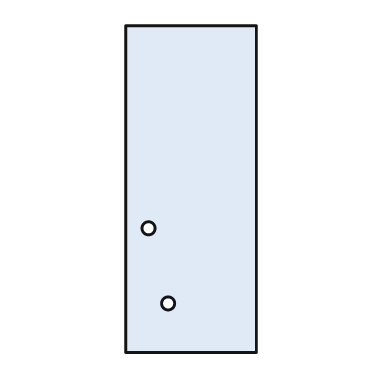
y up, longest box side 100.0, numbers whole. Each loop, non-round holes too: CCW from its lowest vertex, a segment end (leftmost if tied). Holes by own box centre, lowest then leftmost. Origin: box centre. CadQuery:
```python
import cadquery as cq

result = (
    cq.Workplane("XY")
    .moveTo(-20.0, -50.0)
    .lineTo(20.0, -50.0)
    .lineTo(20.0, 50.0)
    .lineTo(-20.0, 50.0)
    .close()
    .moveTo(-7.0, -35.0)
    .circle(2.0)
    .moveTo(-13.0, -12.0)
    .circle(2.0)
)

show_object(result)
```